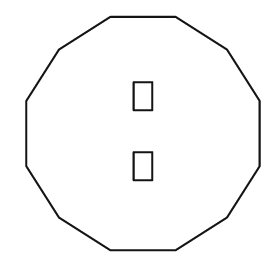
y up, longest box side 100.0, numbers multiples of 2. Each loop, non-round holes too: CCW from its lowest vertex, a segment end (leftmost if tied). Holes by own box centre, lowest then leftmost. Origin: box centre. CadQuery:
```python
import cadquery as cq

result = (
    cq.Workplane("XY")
    .moveTo(-14.0, -50.0)
    .lineTo(14.0, -50.0)
    .lineTo(36.0, -36.0)
    .lineTo(50.0, -14.0)
    .lineTo(50.0, 14.0)
    .lineTo(36.0, 36.0)
    .lineTo(14.0, 50.0)
    .lineTo(-14.0, 50.0)
    .lineTo(-36.0, 36.0)
    .lineTo(-50.0, 14.0)
    .lineTo(-50.0, -14.0)
    .lineTo(-36.0, -36.0)
    .close()
    .moveTo(-4.0, -20.0)
    .lineTo(4.0, -20.0)
    .lineTo(4.0, -8.0)
    .lineTo(-4.0, -8.0)
    .close()
    .moveTo(-4.0, 10.0)
    .lineTo(4.0, 10.0)
    .lineTo(4.0, 22.0)
    .lineTo(-4.0, 22.0)
    .close()
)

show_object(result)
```